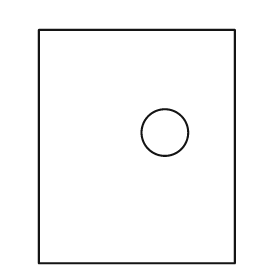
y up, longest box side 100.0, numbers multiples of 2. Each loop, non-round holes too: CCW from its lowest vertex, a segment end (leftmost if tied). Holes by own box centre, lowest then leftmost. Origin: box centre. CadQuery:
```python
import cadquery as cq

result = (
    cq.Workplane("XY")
    .moveTo(-42.0, -50.0)
    .lineTo(42.0, -50.0)
    .lineTo(42.0, 50.0)
    .lineTo(-42.0, 50.0)
    .close()
    .moveTo(12.0, 6.0)
    .circle(10.0)
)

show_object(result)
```